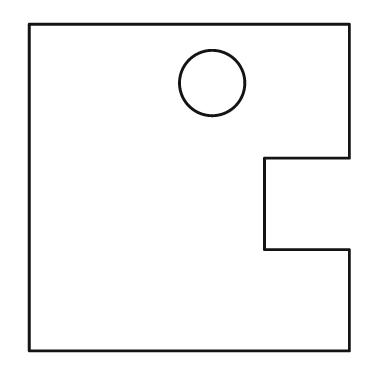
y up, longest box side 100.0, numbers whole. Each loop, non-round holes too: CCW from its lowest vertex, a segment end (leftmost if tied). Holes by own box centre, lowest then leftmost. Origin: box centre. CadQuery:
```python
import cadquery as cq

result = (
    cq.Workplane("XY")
    .moveTo(-49.0, -50.0)
    .lineTo(49.0, -50.0)
    .lineTo(49.0, -19.0)
    .lineTo(23.0, -19.0)
    .lineTo(23.0, 9.0)
    .lineTo(49.0, 9.0)
    .lineTo(49.0, 50.0)
    .lineTo(-49.0, 50.0)
    .close()
    .moveTo(7.0, 32.0)
    .circle(10.0)
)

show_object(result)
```